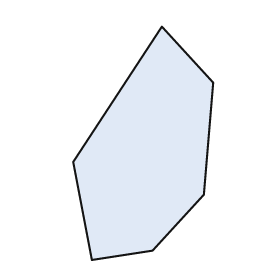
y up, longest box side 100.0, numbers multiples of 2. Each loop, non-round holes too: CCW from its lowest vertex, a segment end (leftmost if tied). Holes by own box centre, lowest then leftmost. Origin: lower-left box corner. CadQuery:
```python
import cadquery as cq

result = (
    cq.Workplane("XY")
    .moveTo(8.0, 0.0)
    .lineTo(34.0, 4.0)
    .lineTo(56.0, 28.0)
    .lineTo(60.0, 76.0)
    .lineTo(38.0, 100.0)
    .lineTo(0.0, 42.0)
    .close()
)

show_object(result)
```